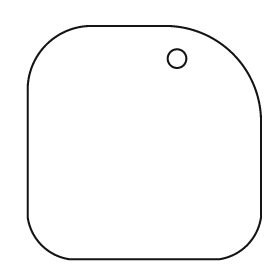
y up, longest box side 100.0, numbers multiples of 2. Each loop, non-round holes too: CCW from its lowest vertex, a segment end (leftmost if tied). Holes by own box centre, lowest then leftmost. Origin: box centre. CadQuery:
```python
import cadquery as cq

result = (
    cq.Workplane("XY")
    .moveTo(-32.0, -50.0)
    .lineTo(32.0, -50.0)
    .threePointArc((44.0, -44.0), (50.0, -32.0))
    .lineTo(50.0, 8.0)
    .threePointArc((38.0, 38.0), (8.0, 50.0))
    .lineTo(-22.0, 50.0)
    .threePointArc((-42.0, 42.0), (-50.0, 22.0))
    .lineTo(-50.0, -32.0)
    .threePointArc((-44.0, -44.0), (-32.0, -50.0))
    .close()
    .moveTo(14.0, 36.0)
    .circle(4.0)
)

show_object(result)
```